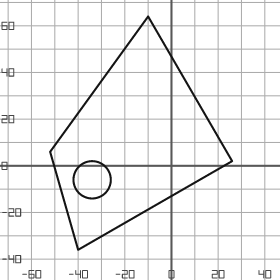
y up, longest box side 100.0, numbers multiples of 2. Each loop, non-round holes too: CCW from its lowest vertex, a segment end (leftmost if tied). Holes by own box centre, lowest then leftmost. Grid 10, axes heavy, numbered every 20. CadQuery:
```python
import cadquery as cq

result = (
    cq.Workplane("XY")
    .moveTo(-40.0, -36.0)
    .lineTo(26.0, 2.0)
    .lineTo(-10.0, 64.0)
    .lineTo(-52.0, 6.0)
    .close()
    .moveTo(-34.0, -6.0)
    .circle(8.0)
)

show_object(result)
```